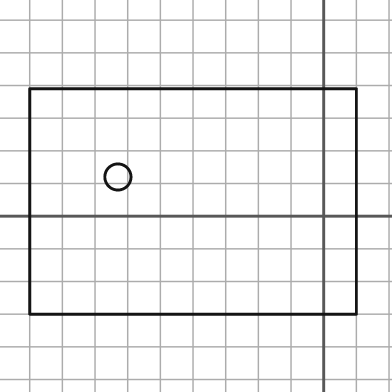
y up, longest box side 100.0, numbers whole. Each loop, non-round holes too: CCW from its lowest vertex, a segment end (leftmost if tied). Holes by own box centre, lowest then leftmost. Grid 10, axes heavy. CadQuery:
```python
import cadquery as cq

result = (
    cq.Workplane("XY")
    .moveTo(-90.0, -30.0)
    .lineTo(10.0, -30.0)
    .lineTo(10.0, 39.0)
    .lineTo(-90.0, 39.0)
    .close()
    .moveTo(-63.0, 12.0)
    .circle(4.0)
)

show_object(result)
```